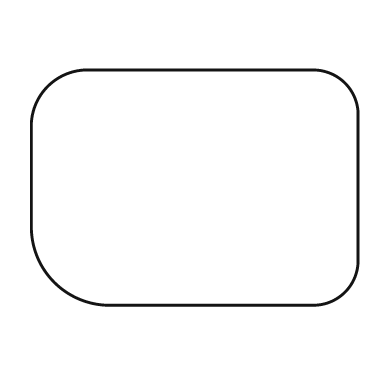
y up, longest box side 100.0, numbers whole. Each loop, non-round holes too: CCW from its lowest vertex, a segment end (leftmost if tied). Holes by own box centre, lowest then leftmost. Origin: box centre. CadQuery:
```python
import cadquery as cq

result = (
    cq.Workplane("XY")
    .moveTo(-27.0, -36.0)
    .lineTo(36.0, -36.0)
    .threePointArc((46.0, -32.0), (50.0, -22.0))
    .lineTo(50.0, 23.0)
    .threePointArc((46.0, 32.0), (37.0, 36.0))
    .lineTo(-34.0, 36.0)
    .threePointArc((-45.0, 31.0), (-50.0, 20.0))
    .lineTo(-50.0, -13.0)
    .threePointArc((-43.0, -29.0), (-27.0, -36.0))
    .close()
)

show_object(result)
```